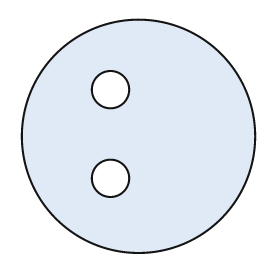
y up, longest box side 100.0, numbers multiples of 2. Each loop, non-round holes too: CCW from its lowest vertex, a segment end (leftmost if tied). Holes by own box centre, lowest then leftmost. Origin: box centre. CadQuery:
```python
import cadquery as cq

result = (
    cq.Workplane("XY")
    .moveTo(0.0, 0.0)
    .circle(50.0)
    .moveTo(-12.0, -18.0)
    .circle(8.0)
    .moveTo(-12.0, 20.0)
    .circle(8.0)
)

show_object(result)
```